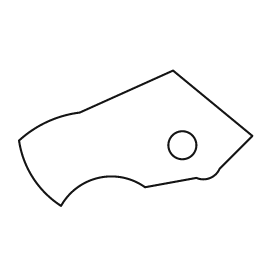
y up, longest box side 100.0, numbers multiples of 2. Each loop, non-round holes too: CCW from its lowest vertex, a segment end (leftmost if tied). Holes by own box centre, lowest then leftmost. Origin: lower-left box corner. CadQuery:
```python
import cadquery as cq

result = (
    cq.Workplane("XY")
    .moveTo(18.0, 0.0)
    .threePointArc((34.0, 12.0), (54.0, 8.0))
    .lineTo(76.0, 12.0)
    .threePointArc((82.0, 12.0), (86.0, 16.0))
    .lineTo(100.0, 30.0)
    .lineTo(66.0, 58.0)
    .lineTo(26.0, 40.0)
    .threePointArc((12.0, 36.0), (0.0, 28.0))
    .threePointArc((6.0, 12.0), (18.0, 0.0))
    .close()
    .moveTo(70.0, 26.0)
    .circle(6.0)
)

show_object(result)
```